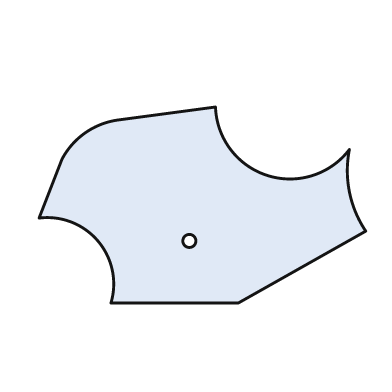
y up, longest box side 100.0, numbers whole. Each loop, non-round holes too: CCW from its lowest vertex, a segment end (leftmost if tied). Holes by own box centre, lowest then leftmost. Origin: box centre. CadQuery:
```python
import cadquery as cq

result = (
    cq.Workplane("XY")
    .moveTo(-28.0, -30.0)
    .lineTo(11.0, -30.0)
    .lineTo(50.0, -8.0)
    .threePointArc((45.0, 4.0), (45.0, 17.0))
    .threePointArc((20.0, 9.0), (4.0, 30.0))
    .lineTo(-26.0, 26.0)
    .threePointArc((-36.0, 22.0), (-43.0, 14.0))
    .lineTo(-50.0, -4.0)
    .threePointArc((-32.0, -11.0), (-28.0, -30.0))
    .close()
    .moveTo(-4.0, -11.0)
    .circle(2.0)
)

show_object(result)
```